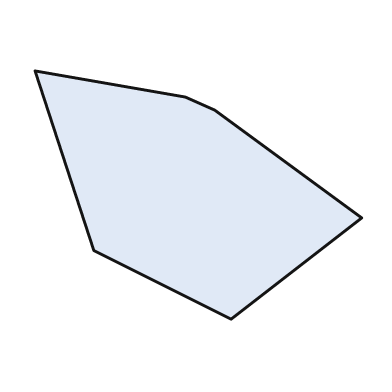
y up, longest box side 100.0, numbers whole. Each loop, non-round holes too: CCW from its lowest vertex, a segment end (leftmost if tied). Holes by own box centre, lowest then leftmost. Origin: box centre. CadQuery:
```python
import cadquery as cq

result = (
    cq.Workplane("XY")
    .moveTo(10.0, -38.0)
    .lineTo(50.0, -7.0)
    .lineTo(5.0, 26.0)
    .lineTo(-4.0, 30.0)
    .lineTo(-50.0, 38.0)
    .lineTo(-32.0, -17.0)
    .close()
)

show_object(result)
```